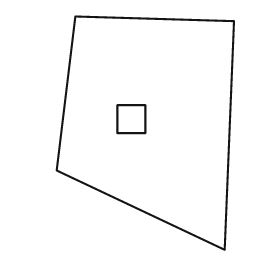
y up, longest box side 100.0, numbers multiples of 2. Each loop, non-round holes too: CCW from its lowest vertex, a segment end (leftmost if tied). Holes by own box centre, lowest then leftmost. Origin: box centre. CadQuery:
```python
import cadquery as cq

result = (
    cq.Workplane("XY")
    .moveTo(34.0, -50.0)
    .lineTo(38.0, 48.0)
    .lineTo(-30.0, 50.0)
    .lineTo(-38.0, -16.0)
    .close()
    .moveTo(-12.0, 0.0)
    .lineTo(0.0, 0.0)
    .lineTo(0.0, 12.0)
    .lineTo(-12.0, 12.0)
    .close()
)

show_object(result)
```